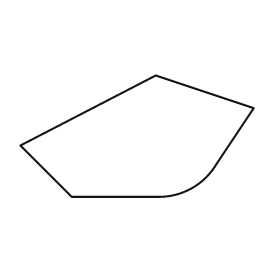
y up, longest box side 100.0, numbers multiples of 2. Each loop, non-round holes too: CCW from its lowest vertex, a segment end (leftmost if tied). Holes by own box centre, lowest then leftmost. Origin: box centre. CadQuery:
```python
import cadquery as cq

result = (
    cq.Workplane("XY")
    .moveTo(-28.0, -26.0)
    .lineTo(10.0, -26.0)
    .threePointArc((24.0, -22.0), (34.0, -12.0))
    .lineTo(50.0, 12.0)
    .lineTo(8.0, 26.0)
    .lineTo(-50.0, -4.0)
    .close()
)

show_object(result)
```